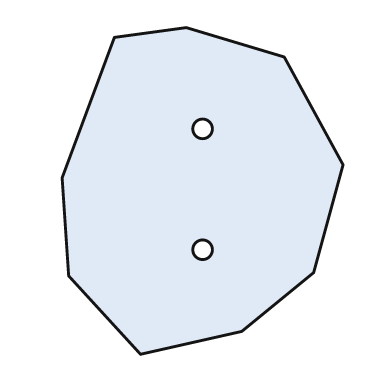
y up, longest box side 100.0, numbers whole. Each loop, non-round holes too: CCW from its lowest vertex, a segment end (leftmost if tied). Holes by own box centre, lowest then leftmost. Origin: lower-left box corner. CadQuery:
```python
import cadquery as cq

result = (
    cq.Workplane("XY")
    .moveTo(24.0, 0.0)
    .lineTo(55.0, 7.0)
    .lineTo(77.0, 25.0)
    .lineTo(86.0, 58.0)
    .lineTo(68.0, 91.0)
    .lineTo(38.0, 100.0)
    .lineTo(16.0, 97.0)
    .lineTo(0.0, 54.0)
    .lineTo(2.0, 24.0)
    .close()
    .moveTo(43.0, 32.0)
    .circle(3.0)
    .moveTo(43.0, 69.0)
    .circle(3.0)
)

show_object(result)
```